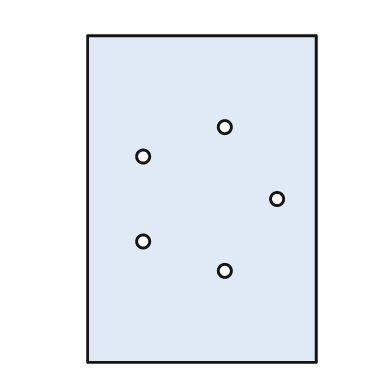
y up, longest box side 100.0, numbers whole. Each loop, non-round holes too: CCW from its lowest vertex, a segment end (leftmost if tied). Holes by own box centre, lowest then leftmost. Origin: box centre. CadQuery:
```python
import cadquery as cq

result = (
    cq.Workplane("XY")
    .moveTo(-35.0, -50.0)
    .lineTo(35.0, -50.0)
    .lineTo(35.0, 50.0)
    .lineTo(-35.0, 50.0)
    .close()
    .moveTo(7.0, -22.0)
    .circle(2.0)
    .moveTo(-18.0, -13.0)
    .circle(2.0)
    .moveTo(23.0, 0.0)
    .circle(2.0)
    .moveTo(-18.0, 13.0)
    .circle(2.0)
    .moveTo(7.0, 22.0)
    .circle(2.0)
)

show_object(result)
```